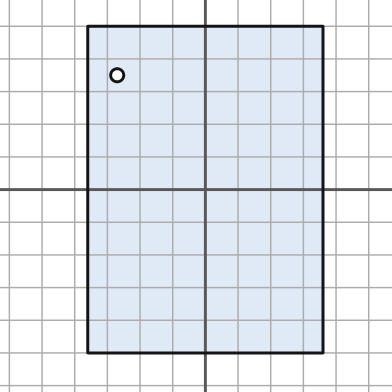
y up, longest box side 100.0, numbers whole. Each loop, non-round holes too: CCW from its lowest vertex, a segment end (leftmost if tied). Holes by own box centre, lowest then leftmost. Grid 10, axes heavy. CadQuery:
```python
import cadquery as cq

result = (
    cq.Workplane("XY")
    .moveTo(-36.0, -50.0)
    .lineTo(36.0, -50.0)
    .lineTo(36.0, 50.0)
    .lineTo(-36.0, 50.0)
    .close()
    .moveTo(-27.0, 35.0)
    .circle(2.0)
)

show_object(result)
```